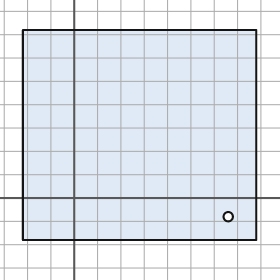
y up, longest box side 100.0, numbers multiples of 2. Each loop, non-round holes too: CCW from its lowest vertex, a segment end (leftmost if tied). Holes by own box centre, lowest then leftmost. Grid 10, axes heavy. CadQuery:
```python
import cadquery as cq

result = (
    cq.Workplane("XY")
    .moveTo(-22.0, -18.0)
    .lineTo(78.0, -18.0)
    .lineTo(78.0, 72.0)
    .lineTo(-22.0, 72.0)
    .close()
    .moveTo(66.0, -8.0)
    .circle(2.0)
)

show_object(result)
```